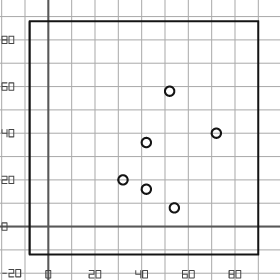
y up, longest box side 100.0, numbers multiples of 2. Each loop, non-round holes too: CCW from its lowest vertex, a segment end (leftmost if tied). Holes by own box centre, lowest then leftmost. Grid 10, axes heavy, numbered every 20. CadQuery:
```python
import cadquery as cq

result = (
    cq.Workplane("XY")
    .moveTo(-8.0, -12.0)
    .lineTo(90.0, -12.0)
    .lineTo(90.0, 88.0)
    .lineTo(-8.0, 88.0)
    .close()
    .moveTo(54.0, 8.0)
    .circle(2.0)
    .moveTo(42.0, 16.0)
    .circle(2.0)
    .moveTo(32.0, 20.0)
    .circle(2.0)
    .moveTo(42.0, 36.0)
    .circle(2.0)
    .moveTo(72.0, 40.0)
    .circle(2.0)
    .moveTo(52.0, 58.0)
    .circle(2.0)
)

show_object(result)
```